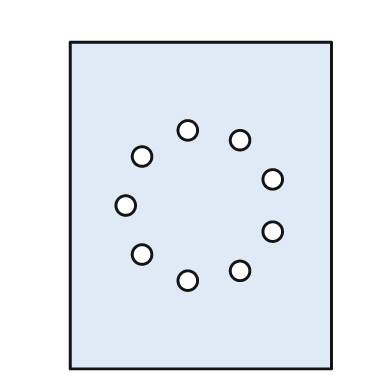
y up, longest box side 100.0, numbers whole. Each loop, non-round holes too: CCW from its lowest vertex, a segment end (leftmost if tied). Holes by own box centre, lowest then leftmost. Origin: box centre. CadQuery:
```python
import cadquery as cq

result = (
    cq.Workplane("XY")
    .moveTo(-40.0, -50.0)
    .lineTo(40.0, -50.0)
    .lineTo(40.0, 50.0)
    .lineTo(-40.0, 50.0)
    .close()
    .moveTo(-4.0, -23.0)
    .circle(3.0)
    .moveTo(12.0, -20.0)
    .circle(3.0)
    .moveTo(-18.0, -15.0)
    .circle(3.0)
    .moveTo(22.0, -8.0)
    .circle(3.0)
    .moveTo(-23.0, 0.0)
    .circle(3.0)
    .moveTo(22.0, 8.0)
    .circle(3.0)
    .moveTo(-18.0, 15.0)
    .circle(3.0)
    .moveTo(12.0, 20.0)
    .circle(3.0)
    .moveTo(-4.0, 23.0)
    .circle(3.0)
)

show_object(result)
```